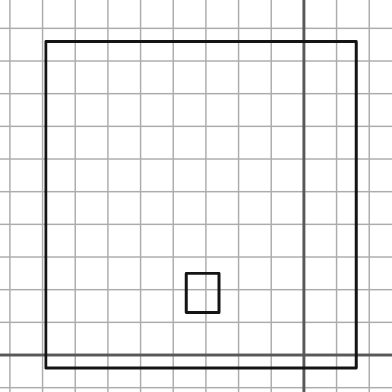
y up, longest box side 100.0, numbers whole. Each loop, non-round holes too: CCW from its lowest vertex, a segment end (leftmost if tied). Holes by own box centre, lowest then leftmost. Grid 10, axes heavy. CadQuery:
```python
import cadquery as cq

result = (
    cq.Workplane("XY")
    .moveTo(-79.0, -4.0)
    .lineTo(16.0, -4.0)
    .lineTo(16.0, 96.0)
    .lineTo(-79.0, 96.0)
    .close()
    .moveTo(-36.0, 13.0)
    .lineTo(-26.0, 13.0)
    .lineTo(-26.0, 25.0)
    .lineTo(-36.0, 25.0)
    .close()
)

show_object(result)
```